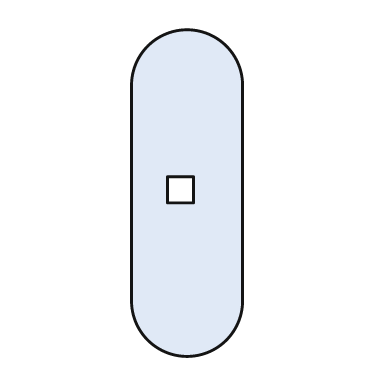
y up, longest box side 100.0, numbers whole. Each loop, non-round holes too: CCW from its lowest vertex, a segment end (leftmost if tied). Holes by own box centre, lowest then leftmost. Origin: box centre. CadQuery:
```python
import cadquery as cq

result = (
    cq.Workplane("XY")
    .moveTo(-17.0, -33.0)
    .threePointArc((0.0, -50.0), (17.0, -33.0))
    .lineTo(17.0, 33.0)
    .threePointArc((0.0, 50.0), (-17.0, 33.0))
    .close()
    .moveTo(-6.0, -3.0)
    .lineTo(2.0, -3.0)
    .lineTo(2.0, 5.0)
    .lineTo(-6.0, 5.0)
    .close()
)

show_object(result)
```